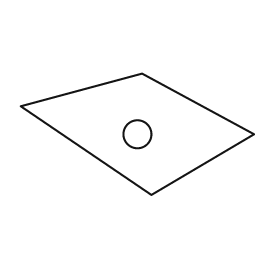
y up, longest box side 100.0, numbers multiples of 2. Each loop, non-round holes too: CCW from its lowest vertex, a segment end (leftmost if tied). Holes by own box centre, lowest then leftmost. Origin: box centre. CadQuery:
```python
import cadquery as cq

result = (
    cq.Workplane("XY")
    .moveTo(6.0, -26.0)
    .lineTo(50.0, 0.0)
    .lineTo(2.0, 26.0)
    .lineTo(-50.0, 12.0)
    .close()
    .moveTo(0.0, 0.0)
    .circle(6.0)
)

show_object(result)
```